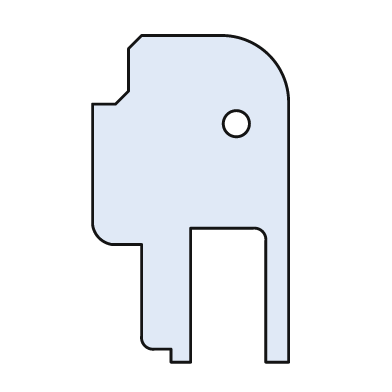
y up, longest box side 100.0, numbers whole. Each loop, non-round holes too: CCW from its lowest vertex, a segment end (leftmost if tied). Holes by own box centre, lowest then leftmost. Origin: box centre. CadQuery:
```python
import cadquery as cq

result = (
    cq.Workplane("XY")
    .moveTo(-6.0, -50.0)
    .lineTo(0.0, -50.0)
    .lineTo(0.0, -9.0)
    .lineTo(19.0, -9.0)
    .threePointArc((22.0, -10.0), (23.0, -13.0))
    .lineTo(23.0, -50.0)
    .lineTo(30.0, -50.0)
    .lineTo(30.0, 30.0)
    .threePointArc((24.0, 44.0), (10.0, 50.0))
    .lineTo(-15.0, 50.0)
    .lineTo(-19.0, 46.0)
    .lineTo(-19.0, 33.0)
    .lineTo(-23.0, 29.0)
    .lineTo(-30.0, 29.0)
    .lineTo(-30.0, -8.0)
    .threePointArc((-28.0, -12.0), (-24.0, -14.0))
    .lineTo(-15.0, -14.0)
    .lineTo(-15.0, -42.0)
    .threePointArc((-14.0, -45.0), (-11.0, -46.0))
    .lineTo(-6.0, -46.0)
    .close()
    .moveTo(14.0, 23.0)
    .circle(4.0)
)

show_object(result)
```